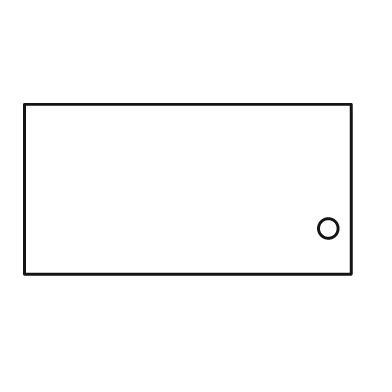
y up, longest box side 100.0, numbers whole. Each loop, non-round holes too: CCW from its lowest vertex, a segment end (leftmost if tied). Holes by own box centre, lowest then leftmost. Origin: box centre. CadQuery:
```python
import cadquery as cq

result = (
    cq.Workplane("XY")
    .moveTo(-50.0, -26.0)
    .lineTo(50.0, -26.0)
    .lineTo(50.0, 26.0)
    .lineTo(-50.0, 26.0)
    .close()
    .moveTo(43.0, -12.0)
    .circle(3.0)
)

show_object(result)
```